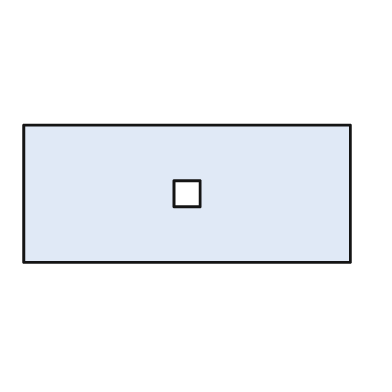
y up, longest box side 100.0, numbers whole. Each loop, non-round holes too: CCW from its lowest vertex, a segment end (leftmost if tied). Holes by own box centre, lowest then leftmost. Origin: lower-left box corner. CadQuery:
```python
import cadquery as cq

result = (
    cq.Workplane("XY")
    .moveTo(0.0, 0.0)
    .lineTo(100.0, 0.0)
    .lineTo(100.0, 42.0)
    .lineTo(0.0, 42.0)
    .close()
    .moveTo(46.0, 17.0)
    .lineTo(54.0, 17.0)
    .lineTo(54.0, 25.0)
    .lineTo(46.0, 25.0)
    .close()
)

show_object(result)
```